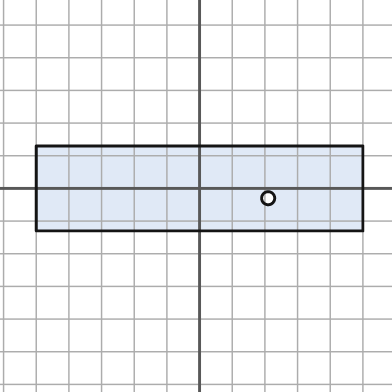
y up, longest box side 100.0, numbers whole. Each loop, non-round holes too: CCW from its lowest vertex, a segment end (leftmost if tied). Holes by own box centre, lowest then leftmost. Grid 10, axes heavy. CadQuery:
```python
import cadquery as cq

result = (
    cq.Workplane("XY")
    .moveTo(-50.0, -13.0)
    .lineTo(50.0, -13.0)
    .lineTo(50.0, 13.0)
    .lineTo(-50.0, 13.0)
    .close()
    .moveTo(21.0, -3.0)
    .circle(2.0)
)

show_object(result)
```